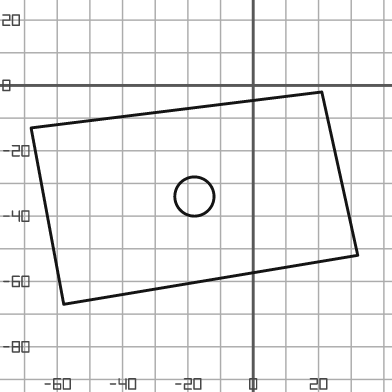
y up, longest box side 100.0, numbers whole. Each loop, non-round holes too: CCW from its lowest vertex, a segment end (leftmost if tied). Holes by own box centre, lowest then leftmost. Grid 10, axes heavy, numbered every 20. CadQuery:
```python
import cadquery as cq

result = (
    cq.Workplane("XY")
    .moveTo(-58.0, -67.0)
    .lineTo(32.0, -52.0)
    .lineTo(21.0, -2.0)
    .lineTo(-68.0, -13.0)
    .close()
    .moveTo(-18.0, -34.0)
    .circle(6.0)
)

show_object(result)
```